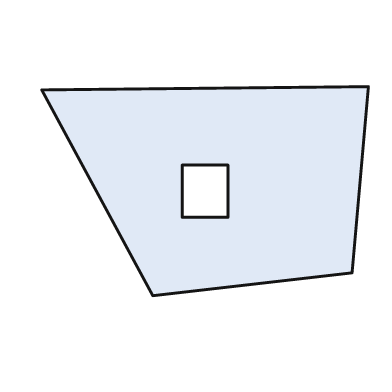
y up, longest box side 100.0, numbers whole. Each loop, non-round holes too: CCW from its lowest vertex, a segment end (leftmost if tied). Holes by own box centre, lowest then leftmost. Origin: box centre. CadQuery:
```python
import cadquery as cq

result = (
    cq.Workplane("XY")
    .moveTo(-16.0, -32.0)
    .lineTo(45.0, -25.0)
    .lineTo(50.0, 32.0)
    .lineTo(-50.0, 31.0)
    .close()
    .moveTo(-7.0, -8.0)
    .lineTo(7.0, -8.0)
    .lineTo(7.0, 8.0)
    .lineTo(-7.0, 8.0)
    .close()
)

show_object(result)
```